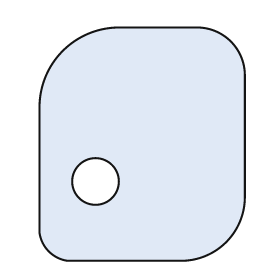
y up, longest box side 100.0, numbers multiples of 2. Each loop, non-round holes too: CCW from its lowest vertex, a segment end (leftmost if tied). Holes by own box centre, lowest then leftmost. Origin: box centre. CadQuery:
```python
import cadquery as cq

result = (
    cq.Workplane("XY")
    .moveTo(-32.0, -50.0)
    .lineTo(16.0, -50.0)
    .threePointArc((36.0, -42.0), (44.0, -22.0))
    .lineTo(44.0, 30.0)
    .threePointArc((38.0, 44.0), (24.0, 50.0))
    .lineTo(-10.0, 50.0)
    .threePointArc((-34.0, 40.0), (-44.0, 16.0))
    .lineTo(-44.0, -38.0)
    .threePointArc((-40.0, -46.0), (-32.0, -50.0))
    .close()
    .moveTo(-20.0, -16.0)
    .circle(10.0)
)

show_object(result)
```